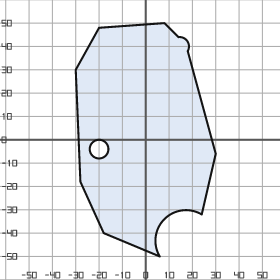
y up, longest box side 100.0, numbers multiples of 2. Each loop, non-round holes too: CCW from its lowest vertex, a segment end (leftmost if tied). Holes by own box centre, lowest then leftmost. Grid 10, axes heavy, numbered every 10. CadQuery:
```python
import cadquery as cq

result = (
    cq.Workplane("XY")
    .moveTo(6.0, -50.0)
    .threePointArc((8.0, -34.0), (24.0, -32.0))
    .lineTo(30.0, -6.0)
    .lineTo(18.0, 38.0)
    .threePointArc((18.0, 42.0), (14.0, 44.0))
    .lineTo(8.0, 50.0)
    .lineTo(-20.0, 48.0)
    .lineTo(-30.0, 30.0)
    .lineTo(-28.0, -18.0)
    .lineTo(-18.0, -40.0)
    .close()
    .moveTo(-20.0, -4.0)
    .circle(4.0)
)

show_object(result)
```